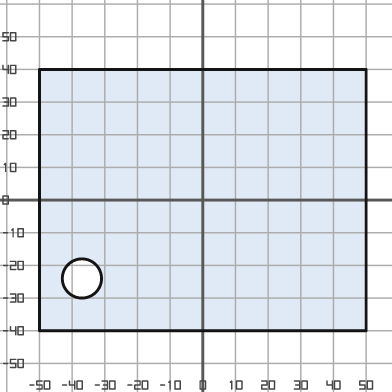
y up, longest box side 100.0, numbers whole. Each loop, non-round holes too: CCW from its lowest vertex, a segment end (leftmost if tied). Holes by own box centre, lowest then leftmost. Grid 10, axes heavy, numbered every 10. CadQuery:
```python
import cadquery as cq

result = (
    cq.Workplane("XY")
    .moveTo(-50.0, -40.0)
    .lineTo(50.0, -40.0)
    .lineTo(50.0, 40.0)
    .lineTo(-50.0, 40.0)
    .close()
    .moveTo(-37.0, -24.0)
    .circle(6.0)
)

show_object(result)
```